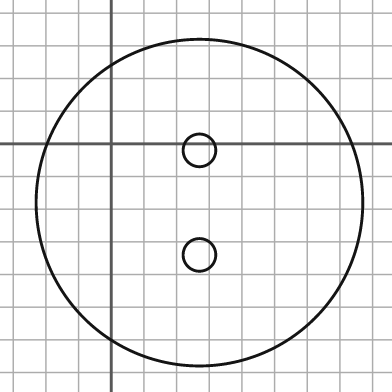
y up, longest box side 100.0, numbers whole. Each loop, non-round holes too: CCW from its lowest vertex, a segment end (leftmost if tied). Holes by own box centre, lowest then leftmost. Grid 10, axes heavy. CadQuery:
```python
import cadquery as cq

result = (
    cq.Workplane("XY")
    .moveTo(27.0, -18.0)
    .circle(50.0)
    .moveTo(27.0, -34.0)
    .circle(5.0)
    .moveTo(27.0, -2.0)
    .circle(5.0)
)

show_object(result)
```